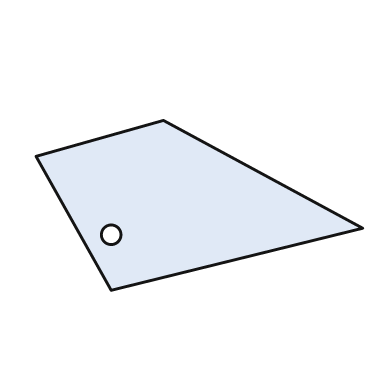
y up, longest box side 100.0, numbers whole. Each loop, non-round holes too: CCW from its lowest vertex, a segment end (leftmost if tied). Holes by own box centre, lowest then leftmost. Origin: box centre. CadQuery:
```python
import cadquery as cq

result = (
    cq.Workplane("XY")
    .moveTo(-27.0, -26.0)
    .lineTo(50.0, -7.0)
    .lineTo(-11.0, 26.0)
    .lineTo(-50.0, 15.0)
    .close()
    .moveTo(-27.0, -9.0)
    .circle(3.0)
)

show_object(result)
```